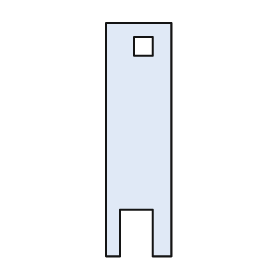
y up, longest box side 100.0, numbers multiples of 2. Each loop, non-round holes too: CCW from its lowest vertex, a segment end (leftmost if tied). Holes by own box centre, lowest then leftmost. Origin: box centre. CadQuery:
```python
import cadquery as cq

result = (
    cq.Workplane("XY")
    .moveTo(-14.0, -50.0)
    .lineTo(-8.0, -50.0)
    .lineTo(-8.0, -30.0)
    .lineTo(6.0, -30.0)
    .lineTo(6.0, -50.0)
    .lineTo(14.0, -50.0)
    .lineTo(14.0, 50.0)
    .lineTo(-14.0, 50.0)
    .close()
    .moveTo(-2.0, 36.0)
    .lineTo(6.0, 36.0)
    .lineTo(6.0, 44.0)
    .lineTo(-2.0, 44.0)
    .close()
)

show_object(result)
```